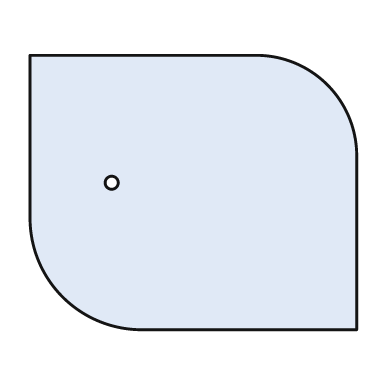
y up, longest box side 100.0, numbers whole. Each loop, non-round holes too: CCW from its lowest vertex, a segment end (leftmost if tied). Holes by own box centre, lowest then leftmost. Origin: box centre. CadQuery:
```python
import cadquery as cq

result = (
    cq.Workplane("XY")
    .moveTo(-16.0, -42.0)
    .lineTo(50.0, -42.0)
    .lineTo(50.0, 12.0)
    .threePointArc((41.0, 33.0), (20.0, 42.0))
    .lineTo(-50.0, 42.0)
    .lineTo(-50.0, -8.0)
    .threePointArc((-40.0, -32.0), (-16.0, -42.0))
    .close()
    .moveTo(-25.0, 3.0)
    .circle(2.0)
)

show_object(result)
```